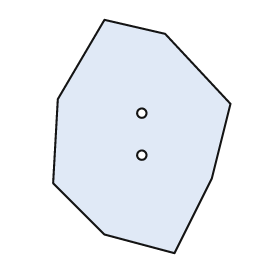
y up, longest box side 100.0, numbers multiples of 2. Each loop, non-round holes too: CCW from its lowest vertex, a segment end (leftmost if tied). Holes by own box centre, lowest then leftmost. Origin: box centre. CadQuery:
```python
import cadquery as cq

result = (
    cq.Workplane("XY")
    .moveTo(14.0, -50.0)
    .lineTo(30.0, -18.0)
    .lineTo(38.0, 14.0)
    .lineTo(10.0, 44.0)
    .lineTo(-16.0, 50.0)
    .lineTo(-36.0, 16.0)
    .lineTo(-38.0, -20.0)
    .lineTo(-16.0, -42.0)
    .close()
    .moveTo(0.0, -8.0)
    .circle(2.0)
    .moveTo(0.0, 10.0)
    .circle(2.0)
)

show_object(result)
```